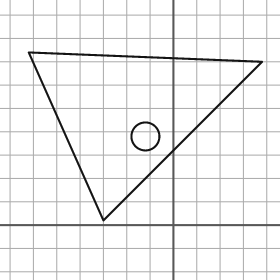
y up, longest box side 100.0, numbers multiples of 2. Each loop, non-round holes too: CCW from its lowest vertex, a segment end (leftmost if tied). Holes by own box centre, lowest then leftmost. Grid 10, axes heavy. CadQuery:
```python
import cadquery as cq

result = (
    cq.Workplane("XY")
    .moveTo(-30.0, 2.0)
    .lineTo(38.0, 70.0)
    .lineTo(-62.0, 74.0)
    .close()
    .moveTo(-12.0, 38.0)
    .circle(6.0)
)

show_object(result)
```